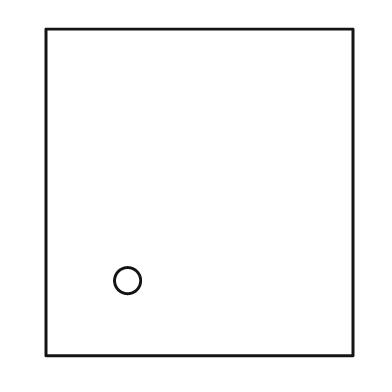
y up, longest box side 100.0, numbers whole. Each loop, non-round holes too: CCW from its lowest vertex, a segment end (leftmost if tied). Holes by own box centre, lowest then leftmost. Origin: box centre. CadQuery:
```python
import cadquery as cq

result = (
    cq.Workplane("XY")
    .moveTo(-47.0, -50.0)
    .lineTo(47.0, -50.0)
    .lineTo(47.0, 50.0)
    .lineTo(-47.0, 50.0)
    .close()
    .moveTo(-22.0, -27.0)
    .circle(4.0)
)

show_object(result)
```